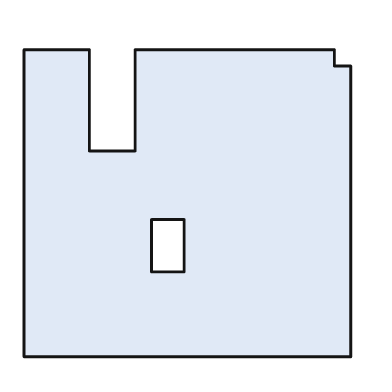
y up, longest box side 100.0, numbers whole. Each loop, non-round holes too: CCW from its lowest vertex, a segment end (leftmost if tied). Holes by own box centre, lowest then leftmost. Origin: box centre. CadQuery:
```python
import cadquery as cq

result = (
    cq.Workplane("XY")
    .moveTo(-50.0, -47.0)
    .lineTo(50.0, -47.0)
    .lineTo(50.0, 42.0)
    .lineTo(45.0, 42.0)
    .lineTo(45.0, 47.0)
    .lineTo(-16.0, 47.0)
    .lineTo(-16.0, 16.0)
    .lineTo(-30.0, 16.0)
    .lineTo(-30.0, 47.0)
    .lineTo(-50.0, 47.0)
    .close()
    .moveTo(-11.0, -21.0)
    .lineTo(-1.0, -21.0)
    .lineTo(-1.0, -5.0)
    .lineTo(-11.0, -5.0)
    .close()
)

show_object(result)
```